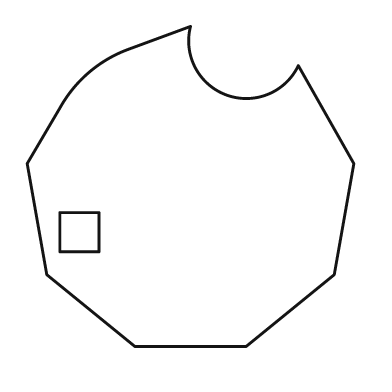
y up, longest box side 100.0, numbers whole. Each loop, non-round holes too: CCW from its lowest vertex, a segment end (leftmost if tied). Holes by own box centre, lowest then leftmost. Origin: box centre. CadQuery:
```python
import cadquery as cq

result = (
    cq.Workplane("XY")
    .moveTo(-17.0, -49.0)
    .lineTo(17.0, -49.0)
    .lineTo(44.0, -27.0)
    .lineTo(50.0, 7.0)
    .lineTo(33.0, 37.0)
    .threePointArc((11.0, 28.0), (0.0, 49.0))
    .lineTo(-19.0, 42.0)
    .threePointArc((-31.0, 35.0), (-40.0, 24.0))
    .lineTo(-50.0, 7.0)
    .lineTo(-44.0, -27.0)
    .close()
    .moveTo(-40.0, -20.0)
    .lineTo(-28.0, -20.0)
    .lineTo(-28.0, -8.0)
    .lineTo(-40.0, -8.0)
    .close()
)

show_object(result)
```